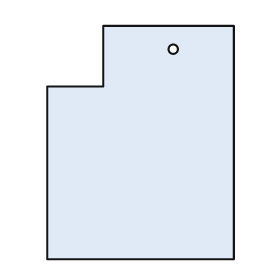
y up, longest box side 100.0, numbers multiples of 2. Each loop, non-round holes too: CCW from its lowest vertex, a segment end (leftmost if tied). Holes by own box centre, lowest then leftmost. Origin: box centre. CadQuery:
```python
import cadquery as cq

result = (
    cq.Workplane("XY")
    .moveTo(-40.0, -50.0)
    .lineTo(40.0, -50.0)
    .lineTo(40.0, 50.0)
    .lineTo(-16.0, 50.0)
    .lineTo(-16.0, 24.0)
    .lineTo(-40.0, 24.0)
    .close()
    .moveTo(14.0, 40.0)
    .circle(2.0)
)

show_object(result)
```